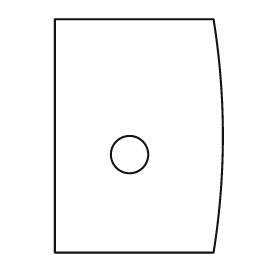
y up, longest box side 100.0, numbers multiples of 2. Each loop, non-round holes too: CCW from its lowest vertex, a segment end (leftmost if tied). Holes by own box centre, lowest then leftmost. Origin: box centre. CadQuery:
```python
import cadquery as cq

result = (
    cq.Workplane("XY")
    .moveTo(-36.0, -50.0)
    .lineTo(32.0, -50.0)
    .threePointArc((36.0, 0.0), (32.0, 50.0))
    .lineTo(-36.0, 50.0)
    .close()
    .moveTo(-4.0, -8.0)
    .circle(8.0)
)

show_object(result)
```